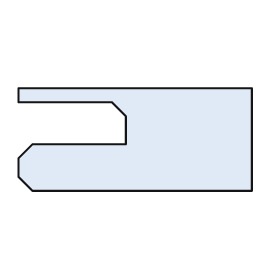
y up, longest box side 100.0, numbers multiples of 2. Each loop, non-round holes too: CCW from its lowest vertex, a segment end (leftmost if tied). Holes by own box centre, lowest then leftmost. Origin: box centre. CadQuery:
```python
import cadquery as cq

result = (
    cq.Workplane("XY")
    .moveTo(-44.0, -22.0)
    .lineTo(50.0, -22.0)
    .lineTo(50.0, 22.0)
    .lineTo(-50.0, 22.0)
    .lineTo(-50.0, 16.0)
    .lineTo(-10.0, 16.0)
    .lineTo(-4.0, 10.0)
    .lineTo(-4.0, -2.0)
    .lineTo(-44.0, -2.0)
    .lineTo(-50.0, -8.0)
    .lineTo(-50.0, -16.0)
    .close()
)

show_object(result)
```